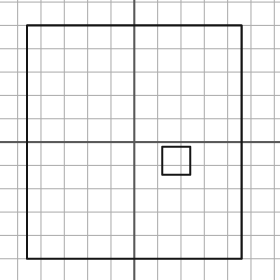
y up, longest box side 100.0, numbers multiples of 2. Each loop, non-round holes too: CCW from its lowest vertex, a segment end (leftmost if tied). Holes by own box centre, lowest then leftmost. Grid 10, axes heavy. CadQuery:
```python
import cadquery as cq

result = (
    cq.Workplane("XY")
    .moveTo(-46.0, -50.0)
    .lineTo(46.0, -50.0)
    .lineTo(46.0, 50.0)
    .lineTo(-46.0, 50.0)
    .close()
    .moveTo(12.0, -14.0)
    .lineTo(24.0, -14.0)
    .lineTo(24.0, -2.0)
    .lineTo(12.0, -2.0)
    .close()
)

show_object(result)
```